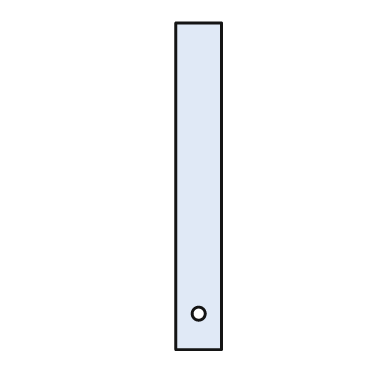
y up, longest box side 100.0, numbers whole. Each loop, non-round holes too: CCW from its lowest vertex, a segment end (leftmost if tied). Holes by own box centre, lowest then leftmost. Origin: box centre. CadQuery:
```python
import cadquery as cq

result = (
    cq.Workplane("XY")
    .moveTo(-7.0, -50.0)
    .lineTo(7.0, -50.0)
    .lineTo(7.0, 50.0)
    .lineTo(-7.0, 50.0)
    .close()
    .moveTo(0.0, -39.0)
    .circle(2.0)
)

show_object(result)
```